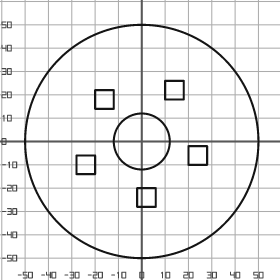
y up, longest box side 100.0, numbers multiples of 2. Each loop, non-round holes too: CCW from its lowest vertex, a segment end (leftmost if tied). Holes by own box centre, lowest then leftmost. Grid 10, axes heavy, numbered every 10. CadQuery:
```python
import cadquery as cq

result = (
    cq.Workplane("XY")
    .moveTo(0.0, 0.0)
    .circle(50.0)
    .moveTo(-2.0, -28.0)
    .lineTo(6.0, -28.0)
    .lineTo(6.0, -20.0)
    .lineTo(-2.0, -20.0)
    .close()
    .moveTo(-28.0, -14.0)
    .lineTo(-20.0, -14.0)
    .lineTo(-20.0, -6.0)
    .lineTo(-28.0, -6.0)
    .close()
    .moveTo(20.0, -10.0)
    .lineTo(28.0, -10.0)
    .lineTo(28.0, -2.0)
    .lineTo(20.0, -2.0)
    .close()
    .moveTo(0.0, 0.0)
    .circle(12.0)
    .moveTo(-20.0, 14.0)
    .lineTo(-12.0, 14.0)
    .lineTo(-12.0, 22.0)
    .lineTo(-20.0, 22.0)
    .close()
    .moveTo(10.0, 18.0)
    .lineTo(18.0, 18.0)
    .lineTo(18.0, 26.0)
    .lineTo(10.0, 26.0)
    .close()
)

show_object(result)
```